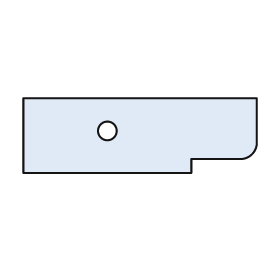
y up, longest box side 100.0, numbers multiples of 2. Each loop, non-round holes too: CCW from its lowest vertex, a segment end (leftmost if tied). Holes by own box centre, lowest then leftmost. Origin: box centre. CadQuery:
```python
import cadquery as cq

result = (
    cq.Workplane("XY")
    .moveTo(-50.0, -16.0)
    .lineTo(22.0, -16.0)
    .lineTo(22.0, -10.0)
    .lineTo(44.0, -10.0)
    .threePointArc((48.0, -8.0), (50.0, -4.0))
    .lineTo(50.0, 16.0)
    .lineTo(-50.0, 16.0)
    .close()
    .moveTo(-14.0, 2.0)
    .circle(4.0)
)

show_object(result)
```